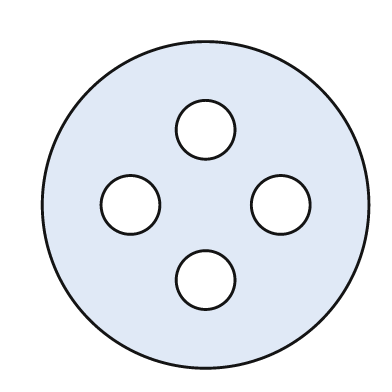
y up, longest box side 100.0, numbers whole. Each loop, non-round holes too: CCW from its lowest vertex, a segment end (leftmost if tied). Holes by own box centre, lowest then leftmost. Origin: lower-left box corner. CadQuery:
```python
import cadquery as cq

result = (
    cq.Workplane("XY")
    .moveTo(50.0, 50.0)
    .circle(50.0)
    .moveTo(50.0, 27.0)
    .circle(9.0)
    .moveTo(27.0, 50.0)
    .circle(9.0)
    .moveTo(73.0, 50.0)
    .circle(9.0)
    .moveTo(50.0, 73.0)
    .circle(9.0)
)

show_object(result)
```